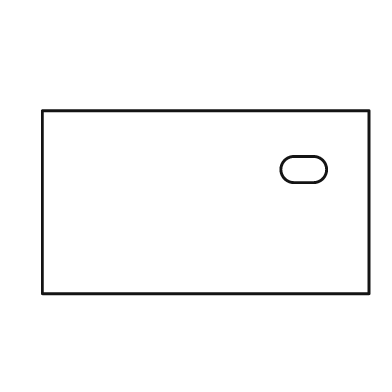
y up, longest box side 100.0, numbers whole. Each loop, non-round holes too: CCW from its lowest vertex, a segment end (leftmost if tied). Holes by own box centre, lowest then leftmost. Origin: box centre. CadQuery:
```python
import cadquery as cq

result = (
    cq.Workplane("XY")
    .moveTo(-50.0, -28.0)
    .lineTo(50.0, -28.0)
    .lineTo(50.0, 28.0)
    .lineTo(-50.0, 28.0)
    .close()
    .moveTo(27.0, 6.0)
    .lineTo(33.0, 6.0)
    .threePointArc((37.0, 10.0), (33.0, 14.0))
    .lineTo(27.0, 14.0)
    .threePointArc((23.0, 10.0), (27.0, 6.0))
    .close()
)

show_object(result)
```